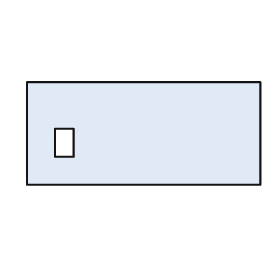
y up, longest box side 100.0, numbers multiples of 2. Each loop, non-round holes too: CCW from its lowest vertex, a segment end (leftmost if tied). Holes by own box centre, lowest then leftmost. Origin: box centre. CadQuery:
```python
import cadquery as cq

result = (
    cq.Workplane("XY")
    .moveTo(-50.0, -22.0)
    .lineTo(50.0, -22.0)
    .lineTo(50.0, 22.0)
    .lineTo(-50.0, 22.0)
    .close()
    .moveTo(-38.0, -10.0)
    .lineTo(-30.0, -10.0)
    .lineTo(-30.0, 2.0)
    .lineTo(-38.0, 2.0)
    .close()
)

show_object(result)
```